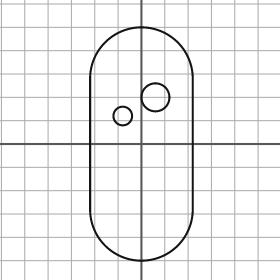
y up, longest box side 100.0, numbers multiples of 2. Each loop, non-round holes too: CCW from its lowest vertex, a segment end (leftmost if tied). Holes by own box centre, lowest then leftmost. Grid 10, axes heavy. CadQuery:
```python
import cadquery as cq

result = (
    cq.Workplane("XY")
    .moveTo(-22.0, -28.0)
    .threePointArc((0.0, -50.0), (22.0, -28.0))
    .lineTo(22.0, 28.0)
    .threePointArc((0.0, 50.0), (-22.0, 28.0))
    .close()
    .moveTo(-8.0, 12.0)
    .circle(4.0)
    .moveTo(6.0, 20.0)
    .circle(6.0)
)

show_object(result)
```